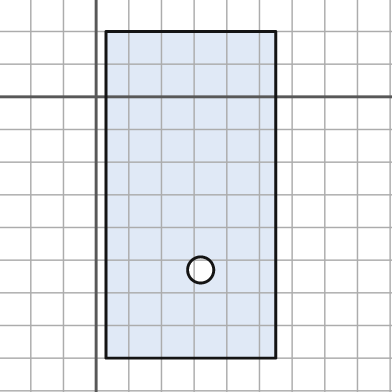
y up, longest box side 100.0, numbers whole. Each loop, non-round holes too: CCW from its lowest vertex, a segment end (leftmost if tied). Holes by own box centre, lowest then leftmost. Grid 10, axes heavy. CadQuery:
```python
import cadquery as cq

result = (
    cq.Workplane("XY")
    .moveTo(3.0, -80.0)
    .lineTo(55.0, -80.0)
    .lineTo(55.0, 20.0)
    .lineTo(3.0, 20.0)
    .close()
    .moveTo(32.0, -53.0)
    .circle(4.0)
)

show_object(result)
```